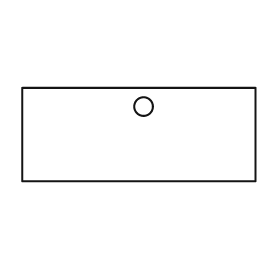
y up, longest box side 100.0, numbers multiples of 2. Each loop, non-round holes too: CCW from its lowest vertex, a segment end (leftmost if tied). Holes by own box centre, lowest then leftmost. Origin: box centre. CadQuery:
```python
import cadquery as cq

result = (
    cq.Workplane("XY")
    .moveTo(-50.0, -20.0)
    .lineTo(50.0, -20.0)
    .lineTo(50.0, 20.0)
    .lineTo(-50.0, 20.0)
    .close()
    .moveTo(2.0, 12.0)
    .circle(4.0)
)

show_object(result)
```